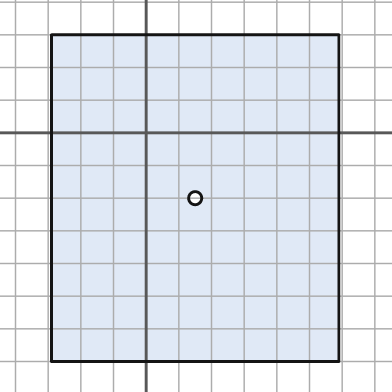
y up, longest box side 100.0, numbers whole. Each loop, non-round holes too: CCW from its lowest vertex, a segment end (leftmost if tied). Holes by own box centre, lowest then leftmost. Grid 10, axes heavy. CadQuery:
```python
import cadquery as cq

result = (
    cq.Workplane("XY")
    .moveTo(-29.0, -70.0)
    .lineTo(59.0, -70.0)
    .lineTo(59.0, 30.0)
    .lineTo(-29.0, 30.0)
    .close()
    .moveTo(15.0, -20.0)
    .circle(2.0)
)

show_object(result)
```